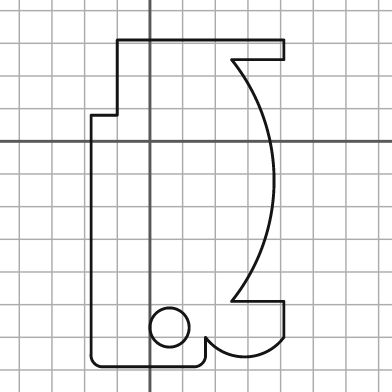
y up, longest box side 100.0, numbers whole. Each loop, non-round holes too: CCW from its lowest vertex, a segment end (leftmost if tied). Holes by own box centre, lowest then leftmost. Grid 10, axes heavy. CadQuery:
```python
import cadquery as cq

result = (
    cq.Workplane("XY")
    .moveTo(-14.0, -69.0)
    .lineTo(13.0, -69.0)
    .threePointArc((16.0, -68.0), (17.0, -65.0))
    .lineTo(17.0, -60.0)
    .threePointArc((29.0, -66.0), (41.0, -60.0))
    .lineTo(41.0, -49.0)
    .lineTo(25.0, -49.0)
    .threePointArc((38.0, -12.0), (25.0, 25.0))
    .lineTo(41.0, 25.0)
    .lineTo(41.0, 31.0)
    .lineTo(-10.0, 31.0)
    .lineTo(-10.0, 8.0)
    .lineTo(-18.0, 8.0)
    .lineTo(-18.0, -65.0)
    .threePointArc((-17.0, -68.0), (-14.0, -69.0))
    .close()
    .moveTo(6.0, -57.0)
    .circle(6.0)
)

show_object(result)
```